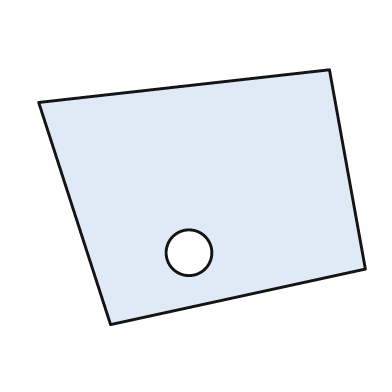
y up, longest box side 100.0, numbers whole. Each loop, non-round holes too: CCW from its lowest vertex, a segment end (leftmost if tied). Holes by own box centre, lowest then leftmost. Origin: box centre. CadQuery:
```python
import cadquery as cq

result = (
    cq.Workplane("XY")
    .moveTo(-28.0, -39.0)
    .lineTo(50.0, -22.0)
    .lineTo(39.0, 39.0)
    .lineTo(-50.0, 29.0)
    .close()
    .moveTo(-4.0, -17.0)
    .circle(7.0)
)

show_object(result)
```